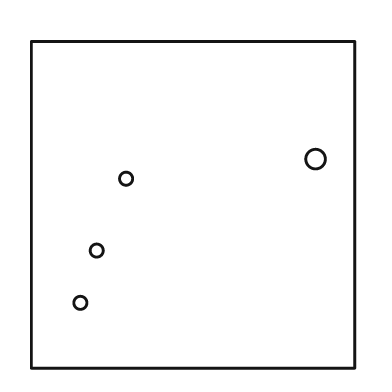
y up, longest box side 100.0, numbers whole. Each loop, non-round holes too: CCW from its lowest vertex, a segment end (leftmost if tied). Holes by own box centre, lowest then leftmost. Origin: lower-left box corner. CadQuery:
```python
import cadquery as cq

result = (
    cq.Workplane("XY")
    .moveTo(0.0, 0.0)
    .lineTo(99.0, 0.0)
    .lineTo(99.0, 100.0)
    .lineTo(0.0, 100.0)
    .close()
    .moveTo(15.0, 20.0)
    .circle(2.0)
    .moveTo(20.0, 36.0)
    .circle(2.0)
    .moveTo(29.0, 58.0)
    .circle(2.0)
    .moveTo(87.0, 64.0)
    .circle(3.0)
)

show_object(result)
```